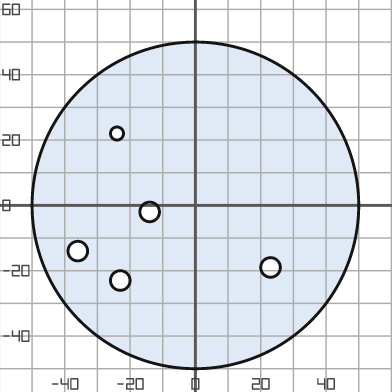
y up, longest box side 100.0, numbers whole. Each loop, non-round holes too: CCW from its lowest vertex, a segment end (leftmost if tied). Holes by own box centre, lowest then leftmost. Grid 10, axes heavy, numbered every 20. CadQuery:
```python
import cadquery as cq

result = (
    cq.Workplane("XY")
    .moveTo(0.0, 0.0)
    .circle(50.0)
    .moveTo(-23.0, -23.0)
    .circle(3.0)
    .moveTo(23.0, -19.0)
    .circle(3.0)
    .moveTo(-36.0, -14.0)
    .circle(3.0)
    .moveTo(-14.0, -2.0)
    .circle(3.0)
    .moveTo(-24.0, 22.0)
    .circle(2.0)
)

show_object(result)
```